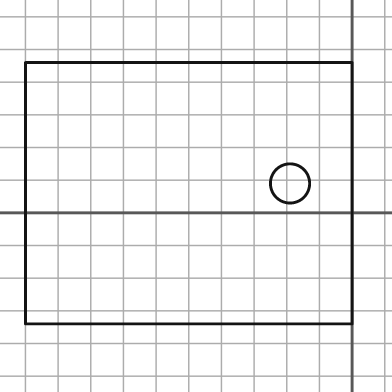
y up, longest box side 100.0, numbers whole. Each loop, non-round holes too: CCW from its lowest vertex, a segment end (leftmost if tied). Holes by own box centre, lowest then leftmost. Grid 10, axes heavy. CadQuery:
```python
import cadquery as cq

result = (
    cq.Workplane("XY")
    .moveTo(-100.0, -34.0)
    .lineTo(0.0, -34.0)
    .lineTo(0.0, 46.0)
    .lineTo(-100.0, 46.0)
    .close()
    .moveTo(-19.0, 9.0)
    .circle(6.0)
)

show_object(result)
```